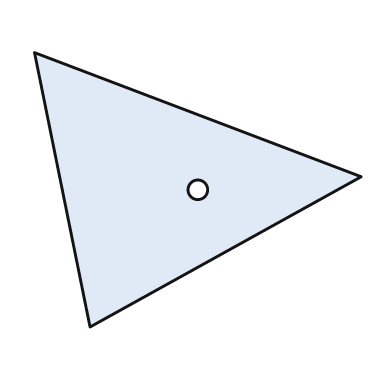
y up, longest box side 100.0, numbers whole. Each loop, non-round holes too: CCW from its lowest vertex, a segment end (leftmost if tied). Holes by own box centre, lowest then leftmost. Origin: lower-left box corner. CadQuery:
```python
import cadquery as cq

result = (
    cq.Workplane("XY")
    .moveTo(17.0, 0.0)
    .lineTo(100.0, 46.0)
    .lineTo(0.0, 84.0)
    .close()
    .moveTo(50.0, 42.0)
    .circle(3.0)
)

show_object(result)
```